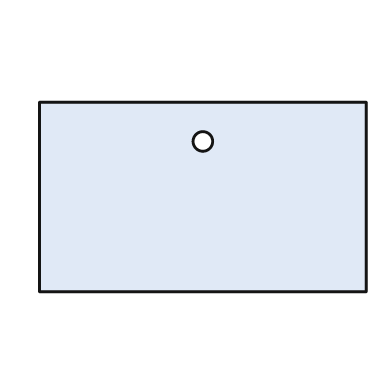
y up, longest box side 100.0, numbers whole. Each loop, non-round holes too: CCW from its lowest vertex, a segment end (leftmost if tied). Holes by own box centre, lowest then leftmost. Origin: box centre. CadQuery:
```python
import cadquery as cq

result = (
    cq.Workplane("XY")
    .moveTo(-50.0, -29.0)
    .lineTo(50.0, -29.0)
    .lineTo(50.0, 29.0)
    .lineTo(-50.0, 29.0)
    .close()
    .moveTo(0.0, 17.0)
    .circle(3.0)
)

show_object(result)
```